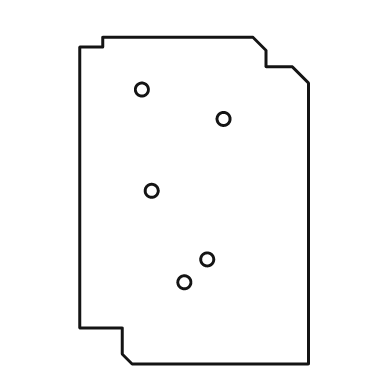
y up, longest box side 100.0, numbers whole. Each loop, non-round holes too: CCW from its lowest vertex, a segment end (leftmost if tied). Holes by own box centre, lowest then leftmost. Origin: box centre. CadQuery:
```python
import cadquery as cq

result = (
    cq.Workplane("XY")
    .moveTo(-19.0, -50.0)
    .lineTo(35.0, -50.0)
    .lineTo(35.0, 36.0)
    .lineTo(30.0, 41.0)
    .lineTo(22.0, 41.0)
    .lineTo(22.0, 46.0)
    .lineTo(18.0, 50.0)
    .lineTo(-28.0, 50.0)
    .lineTo(-28.0, 47.0)
    .lineTo(-35.0, 47.0)
    .lineTo(-35.0, -39.0)
    .lineTo(-22.0, -39.0)
    .lineTo(-22.0, -47.0)
    .close()
    .moveTo(-3.0, -25.0)
    .circle(2.0)
    .moveTo(4.0, -18.0)
    .circle(2.0)
    .moveTo(-13.0, 3.0)
    .circle(2.0)
    .moveTo(9.0, 25.0)
    .circle(2.0)
    .moveTo(-16.0, 34.0)
    .circle(2.0)
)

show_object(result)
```